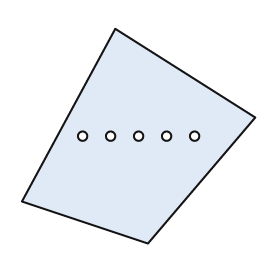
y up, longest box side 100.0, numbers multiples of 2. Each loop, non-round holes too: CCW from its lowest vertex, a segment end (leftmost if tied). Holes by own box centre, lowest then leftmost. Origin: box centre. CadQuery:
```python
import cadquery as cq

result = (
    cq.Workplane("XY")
    .moveTo(4.0, -46.0)
    .lineTo(50.0, 8.0)
    .lineTo(-10.0, 46.0)
    .lineTo(-50.0, -28.0)
    .close()
    .moveTo(-24.0, 0.0)
    .circle(2.0)
    .moveTo(-12.0, 0.0)
    .circle(2.0)
    .moveTo(0.0, 0.0)
    .circle(2.0)
    .moveTo(12.0, 0.0)
    .circle(2.0)
    .moveTo(24.0, 0.0)
    .circle(2.0)
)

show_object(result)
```